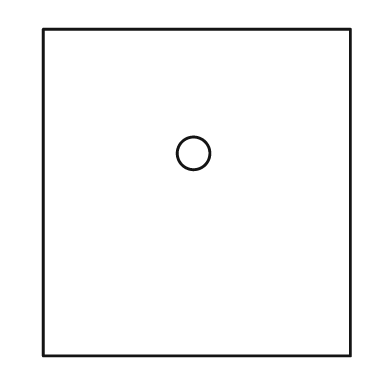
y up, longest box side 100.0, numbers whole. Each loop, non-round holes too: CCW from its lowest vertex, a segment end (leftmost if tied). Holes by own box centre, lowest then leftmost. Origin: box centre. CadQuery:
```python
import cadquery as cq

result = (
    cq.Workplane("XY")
    .moveTo(-47.0, -50.0)
    .lineTo(47.0, -50.0)
    .lineTo(47.0, 50.0)
    .lineTo(-47.0, 50.0)
    .close()
    .moveTo(-1.0, 12.0)
    .circle(5.0)
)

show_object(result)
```